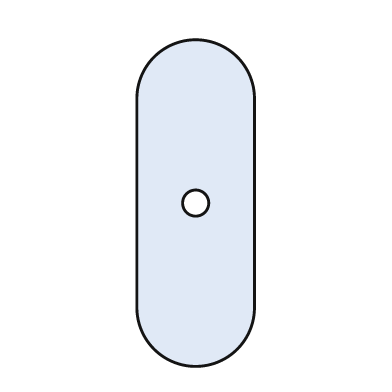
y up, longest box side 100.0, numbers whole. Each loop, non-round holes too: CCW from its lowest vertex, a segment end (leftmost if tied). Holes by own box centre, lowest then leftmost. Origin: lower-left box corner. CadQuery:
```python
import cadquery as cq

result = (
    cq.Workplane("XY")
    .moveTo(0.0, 18.0)
    .threePointArc((18.0, 0.0), (36.0, 18.0))
    .lineTo(36.0, 82.0)
    .threePointArc((18.0, 100.0), (0.0, 82.0))
    .close()
    .moveTo(18.0, 50.0)
    .circle(4.0)
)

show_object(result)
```